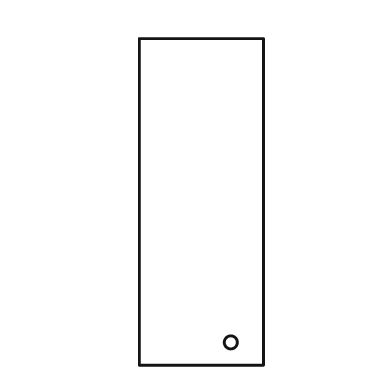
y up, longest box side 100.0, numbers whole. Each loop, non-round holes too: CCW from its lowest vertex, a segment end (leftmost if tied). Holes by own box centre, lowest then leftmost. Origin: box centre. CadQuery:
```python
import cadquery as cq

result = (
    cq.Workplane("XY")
    .moveTo(-19.0, -50.0)
    .lineTo(19.0, -50.0)
    .lineTo(19.0, 50.0)
    .lineTo(-19.0, 50.0)
    .close()
    .moveTo(9.0, -43.0)
    .circle(2.0)
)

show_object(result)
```